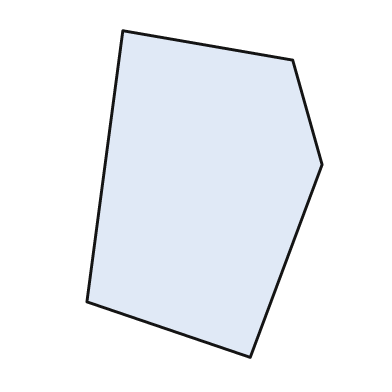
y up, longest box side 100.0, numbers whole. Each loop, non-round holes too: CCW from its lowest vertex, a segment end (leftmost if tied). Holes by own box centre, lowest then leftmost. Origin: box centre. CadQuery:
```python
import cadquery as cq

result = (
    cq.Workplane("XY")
    .moveTo(14.0, -50.0)
    .lineTo(36.0, 9.0)
    .lineTo(27.0, 41.0)
    .lineTo(-25.0, 50.0)
    .lineTo(-36.0, -33.0)
    .close()
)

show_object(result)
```